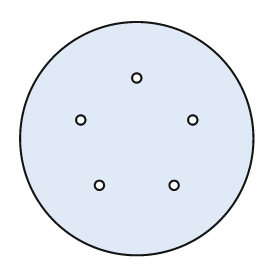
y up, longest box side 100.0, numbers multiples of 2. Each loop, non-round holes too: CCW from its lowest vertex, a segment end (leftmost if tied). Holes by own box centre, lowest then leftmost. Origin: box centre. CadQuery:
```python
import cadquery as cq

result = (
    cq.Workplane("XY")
    .moveTo(0.0, 0.0)
    .circle(50.0)
    .moveTo(-16.0, -20.0)
    .circle(2.0)
    .moveTo(16.0, -20.0)
    .circle(2.0)
    .moveTo(-24.0, 8.0)
    .circle(2.0)
    .moveTo(24.0, 8.0)
    .circle(2.0)
    .moveTo(0.0, 26.0)
    .circle(2.0)
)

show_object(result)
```